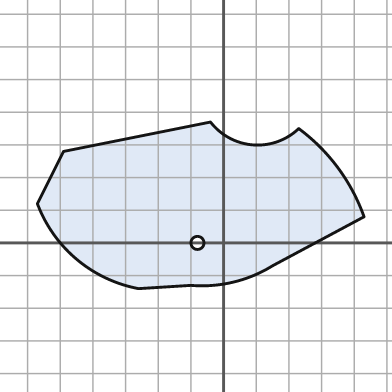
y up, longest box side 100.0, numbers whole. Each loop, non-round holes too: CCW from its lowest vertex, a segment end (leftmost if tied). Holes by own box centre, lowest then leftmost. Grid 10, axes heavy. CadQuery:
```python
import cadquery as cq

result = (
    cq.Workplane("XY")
    .moveTo(-26.0, -14.0)
    .lineTo(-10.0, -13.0)
    .threePointArc((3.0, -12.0), (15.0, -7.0))
    .lineTo(43.0, 8.0)
    .threePointArc((35.0, 23.0), (23.0, 35.0))
    .threePointArc((9.0, 30.0), (-4.0, 37.0))
    .lineTo(-49.0, 28.0)
    .lineTo(-57.0, 12.0)
    .threePointArc((-45.0, -5.0), (-26.0, -14.0))
    .close()
    .moveTo(-8.0, 0.0)
    .circle(2.0)
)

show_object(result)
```